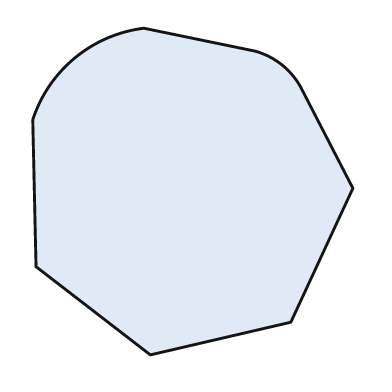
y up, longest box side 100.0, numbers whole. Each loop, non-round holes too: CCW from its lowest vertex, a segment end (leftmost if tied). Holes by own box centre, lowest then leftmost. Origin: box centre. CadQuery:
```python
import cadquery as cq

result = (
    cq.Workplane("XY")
    .moveTo(-13.0, -50.0)
    .lineTo(30.0, -40.0)
    .lineTo(49.0, 1.0)
    .lineTo(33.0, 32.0)
    .threePointArc((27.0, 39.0), (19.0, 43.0))
    .lineTo(-15.0, 50.0)
    .threePointArc((-36.0, 41.0), (-49.0, 22.0))
    .lineTo(-48.0, -23.0)
    .close()
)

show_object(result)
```